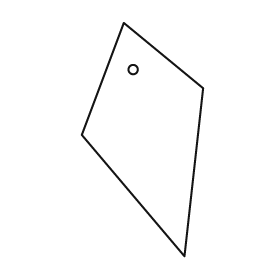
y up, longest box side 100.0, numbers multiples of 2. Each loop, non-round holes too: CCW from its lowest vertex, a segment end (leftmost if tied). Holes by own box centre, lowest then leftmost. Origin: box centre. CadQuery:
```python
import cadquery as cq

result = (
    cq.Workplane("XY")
    .moveTo(18.0, -50.0)
    .lineTo(26.0, 22.0)
    .lineTo(-8.0, 50.0)
    .lineTo(-26.0, 2.0)
    .close()
    .moveTo(-4.0, 30.0)
    .circle(2.0)
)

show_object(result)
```